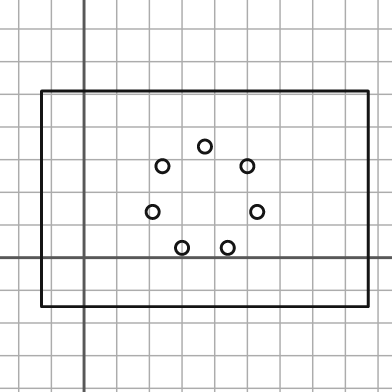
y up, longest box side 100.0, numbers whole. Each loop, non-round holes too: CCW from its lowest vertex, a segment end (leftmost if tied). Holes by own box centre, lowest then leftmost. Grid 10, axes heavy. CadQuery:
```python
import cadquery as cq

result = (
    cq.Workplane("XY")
    .moveTo(-13.0, -15.0)
    .lineTo(87.0, -15.0)
    .lineTo(87.0, 51.0)
    .lineTo(-13.0, 51.0)
    .close()
    .moveTo(30.0, 3.0)
    .circle(2.0)
    .moveTo(44.0, 3.0)
    .circle(2.0)
    .moveTo(21.0, 14.0)
    .circle(2.0)
    .moveTo(53.0, 14.0)
    .circle(2.0)
    .moveTo(24.0, 28.0)
    .circle(2.0)
    .moveTo(50.0, 28.0)
    .circle(2.0)
    .moveTo(37.0, 34.0)
    .circle(2.0)
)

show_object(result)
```